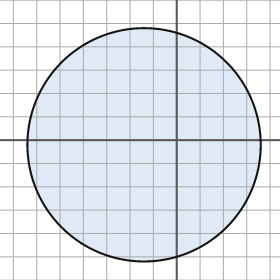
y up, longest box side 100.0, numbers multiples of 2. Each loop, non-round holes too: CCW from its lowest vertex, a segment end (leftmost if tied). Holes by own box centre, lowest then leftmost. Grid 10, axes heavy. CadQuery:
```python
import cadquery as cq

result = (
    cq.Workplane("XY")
    .moveTo(-14.0, -2.0)
    .circle(50.0)
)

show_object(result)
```